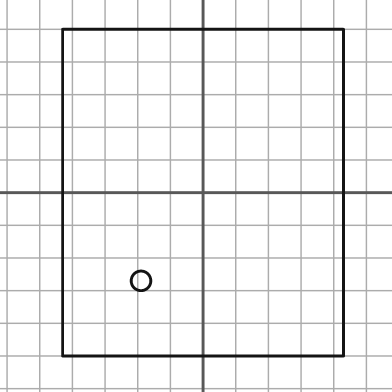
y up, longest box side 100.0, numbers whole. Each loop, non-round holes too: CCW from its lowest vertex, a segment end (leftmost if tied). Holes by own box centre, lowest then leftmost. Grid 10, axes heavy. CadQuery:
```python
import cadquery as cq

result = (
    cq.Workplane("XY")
    .moveTo(-43.0, -50.0)
    .lineTo(43.0, -50.0)
    .lineTo(43.0, 50.0)
    .lineTo(-43.0, 50.0)
    .close()
    .moveTo(-19.0, -27.0)
    .circle(3.0)
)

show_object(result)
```